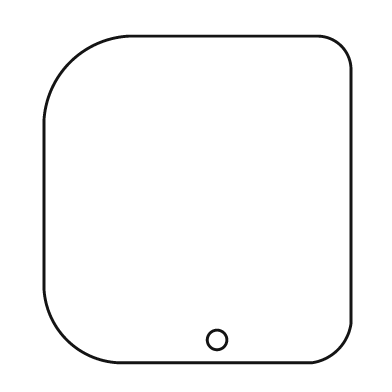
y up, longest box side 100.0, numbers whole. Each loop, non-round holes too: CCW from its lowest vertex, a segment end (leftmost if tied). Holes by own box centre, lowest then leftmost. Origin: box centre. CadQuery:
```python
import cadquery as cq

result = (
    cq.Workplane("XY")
    .moveTo(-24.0, -50.0)
    .lineTo(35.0, -50.0)
    .threePointArc((43.0, -46.0), (47.0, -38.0))
    .lineTo(47.0, 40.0)
    .threePointArc((44.0, 47.0), (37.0, 50.0))
    .lineTo(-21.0, 50.0)
    .threePointArc((-39.0, 42.0), (-47.0, 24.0))
    .lineTo(-47.0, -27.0)
    .threePointArc((-40.0, -43.0), (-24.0, -50.0))
    .close()
    .moveTo(6.0, -43.0)
    .circle(3.0)
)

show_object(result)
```